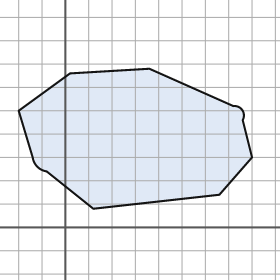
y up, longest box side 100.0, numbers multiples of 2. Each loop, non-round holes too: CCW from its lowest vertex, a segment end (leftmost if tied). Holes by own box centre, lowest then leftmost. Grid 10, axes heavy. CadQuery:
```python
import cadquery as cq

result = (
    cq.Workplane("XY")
    .moveTo(12.0, 8.0)
    .lineTo(66.0, 14.0)
    .lineTo(80.0, 30.0)
    .lineTo(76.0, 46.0)
    .threePointArc((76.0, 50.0), (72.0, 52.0))
    .lineTo(36.0, 68.0)
    .lineTo(2.0, 66.0)
    .lineTo(-20.0, 50.0)
    .lineTo(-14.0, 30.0)
    .threePointArc((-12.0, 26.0), (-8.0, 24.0))
    .close()
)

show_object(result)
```